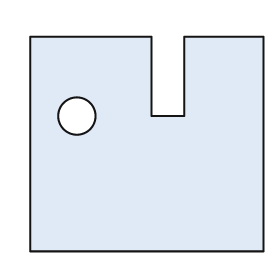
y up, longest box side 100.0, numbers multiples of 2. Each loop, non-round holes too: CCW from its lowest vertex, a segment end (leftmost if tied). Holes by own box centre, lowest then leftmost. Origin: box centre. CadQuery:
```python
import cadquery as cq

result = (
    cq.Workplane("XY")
    .moveTo(-50.0, -46.0)
    .lineTo(50.0, -46.0)
    .lineTo(50.0, 46.0)
    .lineTo(16.0, 46.0)
    .lineTo(16.0, 12.0)
    .lineTo(2.0, 12.0)
    .lineTo(2.0, 46.0)
    .lineTo(-50.0, 46.0)
    .close()
    .moveTo(-30.0, 12.0)
    .circle(8.0)
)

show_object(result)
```